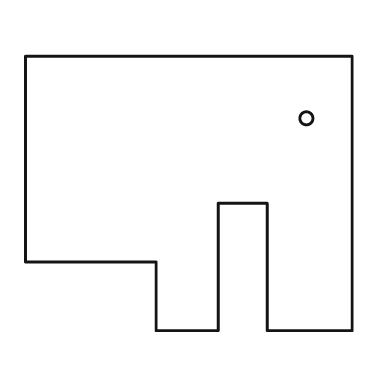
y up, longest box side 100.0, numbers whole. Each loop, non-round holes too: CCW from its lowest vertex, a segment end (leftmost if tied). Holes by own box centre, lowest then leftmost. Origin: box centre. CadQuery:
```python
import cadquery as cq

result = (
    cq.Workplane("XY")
    .moveTo(-10.0, -42.0)
    .lineTo(9.0, -42.0)
    .lineTo(9.0, -3.0)
    .lineTo(24.0, -3.0)
    .lineTo(24.0, -42.0)
    .lineTo(50.0, -42.0)
    .lineTo(50.0, 42.0)
    .lineTo(-50.0, 42.0)
    .lineTo(-50.0, -21.0)
    .lineTo(-10.0, -21.0)
    .close()
    .moveTo(36.0, 23.0)
    .circle(2.0)
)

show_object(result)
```